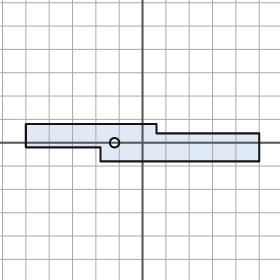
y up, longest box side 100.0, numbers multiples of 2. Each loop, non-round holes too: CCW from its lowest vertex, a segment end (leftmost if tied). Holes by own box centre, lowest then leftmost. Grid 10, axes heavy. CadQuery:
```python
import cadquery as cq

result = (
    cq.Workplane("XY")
    .moveTo(-18.0, -8.0)
    .lineTo(50.0, -8.0)
    .lineTo(50.0, 4.0)
    .lineTo(6.0, 4.0)
    .lineTo(6.0, 8.0)
    .lineTo(-50.0, 8.0)
    .lineTo(-50.0, -2.0)
    .lineTo(-18.0, -2.0)
    .close()
    .moveTo(-12.0, 0.0)
    .circle(2.0)
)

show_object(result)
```